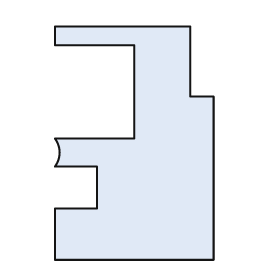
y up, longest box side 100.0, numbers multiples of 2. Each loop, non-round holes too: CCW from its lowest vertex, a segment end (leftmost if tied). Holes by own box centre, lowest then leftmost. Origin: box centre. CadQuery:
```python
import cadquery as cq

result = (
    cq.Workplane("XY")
    .moveTo(-34.0, -50.0)
    .lineTo(34.0, -50.0)
    .lineTo(34.0, 20.0)
    .lineTo(24.0, 20.0)
    .lineTo(24.0, 50.0)
    .lineTo(-34.0, 50.0)
    .lineTo(-34.0, 42.0)
    .lineTo(0.0, 42.0)
    .lineTo(0.0, 2.0)
    .lineTo(-34.0, 2.0)
    .threePointArc((-32.0, -4.0), (-34.0, -10.0))
    .lineTo(-16.0, -10.0)
    .lineTo(-16.0, -28.0)
    .lineTo(-34.0, -28.0)
    .close()
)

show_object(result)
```